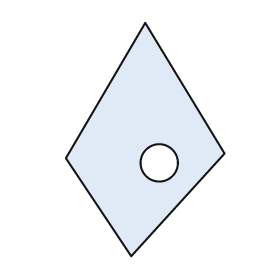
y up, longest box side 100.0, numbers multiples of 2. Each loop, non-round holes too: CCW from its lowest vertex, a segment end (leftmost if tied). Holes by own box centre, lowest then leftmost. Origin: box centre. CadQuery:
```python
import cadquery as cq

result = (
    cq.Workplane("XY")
    .moveTo(-6.0, -50.0)
    .lineTo(34.0, -6.0)
    .lineTo(0.0, 50.0)
    .lineTo(-34.0, -8.0)
    .close()
    .moveTo(6.0, -10.0)
    .circle(8.0)
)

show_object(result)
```